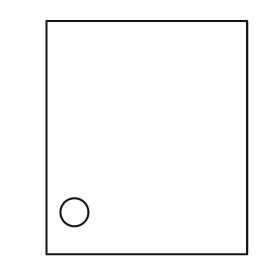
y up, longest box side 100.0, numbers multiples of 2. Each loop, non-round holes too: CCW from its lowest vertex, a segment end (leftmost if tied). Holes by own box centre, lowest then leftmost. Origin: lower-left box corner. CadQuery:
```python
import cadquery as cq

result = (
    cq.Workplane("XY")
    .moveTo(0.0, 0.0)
    .lineTo(86.0, 0.0)
    .lineTo(86.0, 100.0)
    .lineTo(0.0, 100.0)
    .close()
    .moveTo(12.0, 18.0)
    .circle(6.0)
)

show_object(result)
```